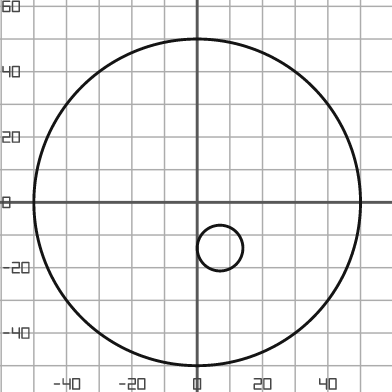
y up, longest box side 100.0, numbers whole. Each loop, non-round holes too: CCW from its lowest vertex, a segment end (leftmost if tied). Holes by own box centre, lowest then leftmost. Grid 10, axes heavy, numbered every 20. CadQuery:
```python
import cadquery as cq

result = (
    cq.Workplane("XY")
    .moveTo(0.0, 0.0)
    .circle(50.0)
    .moveTo(7.0, -14.0)
    .circle(7.0)
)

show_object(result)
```